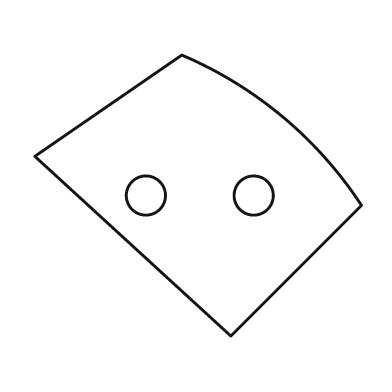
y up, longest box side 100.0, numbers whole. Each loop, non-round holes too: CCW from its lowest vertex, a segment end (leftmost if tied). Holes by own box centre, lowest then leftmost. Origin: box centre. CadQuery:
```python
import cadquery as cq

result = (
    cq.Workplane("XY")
    .moveTo(10.0, -43.0)
    .lineTo(50.0, -3.0)
    .threePointArc((26.0, 24.0), (-5.0, 43.0))
    .lineTo(-50.0, 12.0)
    .close()
    .moveTo(-16.0, 0.0)
    .circle(6.0)
    .moveTo(17.0, 0.0)
    .circle(6.0)
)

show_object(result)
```